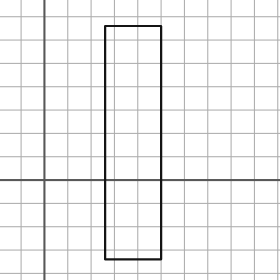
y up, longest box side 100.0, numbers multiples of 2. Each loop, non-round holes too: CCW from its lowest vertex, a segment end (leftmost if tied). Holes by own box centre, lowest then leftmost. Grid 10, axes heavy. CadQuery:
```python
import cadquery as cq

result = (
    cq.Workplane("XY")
    .moveTo(26.0, -34.0)
    .lineTo(50.0, -34.0)
    .lineTo(50.0, 66.0)
    .lineTo(26.0, 66.0)
    .close()
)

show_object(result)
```